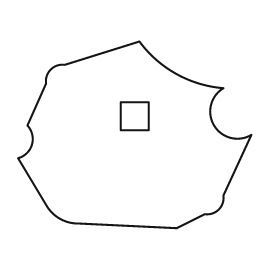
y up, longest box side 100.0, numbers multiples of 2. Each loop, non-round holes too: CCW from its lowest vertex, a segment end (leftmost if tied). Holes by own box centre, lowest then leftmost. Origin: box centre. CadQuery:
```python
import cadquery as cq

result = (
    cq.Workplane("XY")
    .moveTo(18.0, -40.0)
    .lineTo(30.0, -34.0)
    .threePointArc((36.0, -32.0), (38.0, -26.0))
    .lineTo(50.0, 0.0)
    .threePointArc((34.0, 4.0), (38.0, 20.0))
    .threePointArc((18.0, 26.0), (2.0, 40.0))
    .lineTo(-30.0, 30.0)
    .threePointArc((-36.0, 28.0), (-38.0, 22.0))
    .lineTo(-46.0, 4.0)
    .threePointArc((-44.0, -4.0), (-50.0, -10.0))
    .lineTo(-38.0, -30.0)
    .threePointArc((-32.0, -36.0), (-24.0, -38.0))
    .close()
    .moveTo(-6.0, 2.0)
    .lineTo(6.0, 2.0)
    .lineTo(6.0, 14.0)
    .lineTo(-6.0, 14.0)
    .close()
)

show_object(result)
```